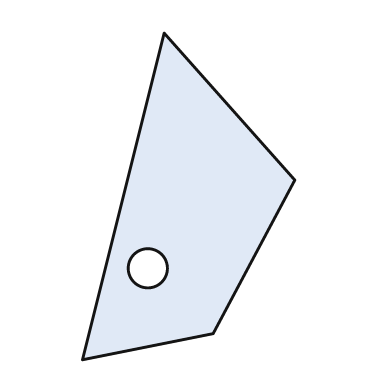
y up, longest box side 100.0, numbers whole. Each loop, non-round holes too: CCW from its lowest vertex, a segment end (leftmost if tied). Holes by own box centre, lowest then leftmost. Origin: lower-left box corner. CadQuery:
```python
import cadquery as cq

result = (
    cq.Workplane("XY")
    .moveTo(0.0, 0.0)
    .lineTo(40.0, 8.0)
    .lineTo(65.0, 55.0)
    .lineTo(25.0, 100.0)
    .close()
    .moveTo(20.0, 28.0)
    .circle(6.0)
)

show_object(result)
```